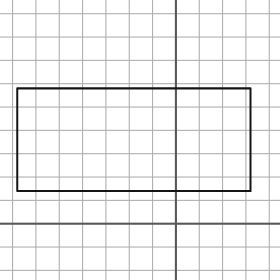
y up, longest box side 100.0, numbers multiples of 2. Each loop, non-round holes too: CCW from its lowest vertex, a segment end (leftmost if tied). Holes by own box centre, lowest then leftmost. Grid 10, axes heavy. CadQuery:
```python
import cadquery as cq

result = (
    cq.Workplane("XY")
    .moveTo(-68.0, 14.0)
    .lineTo(32.0, 14.0)
    .lineTo(32.0, 58.0)
    .lineTo(-68.0, 58.0)
    .close()
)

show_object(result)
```